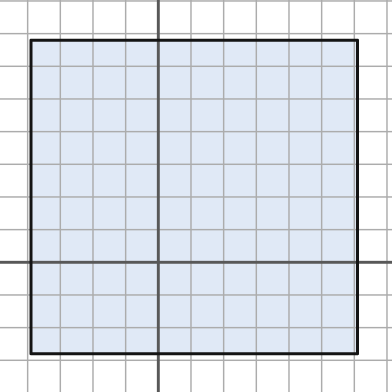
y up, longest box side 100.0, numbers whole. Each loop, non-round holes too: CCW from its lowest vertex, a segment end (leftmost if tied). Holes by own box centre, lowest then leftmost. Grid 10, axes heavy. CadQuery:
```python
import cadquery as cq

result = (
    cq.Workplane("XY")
    .moveTo(-39.0, -28.0)
    .lineTo(61.0, -28.0)
    .lineTo(61.0, 68.0)
    .lineTo(-39.0, 68.0)
    .close()
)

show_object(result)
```